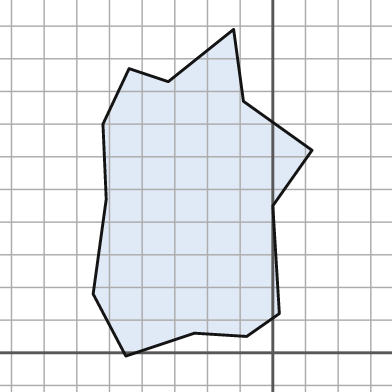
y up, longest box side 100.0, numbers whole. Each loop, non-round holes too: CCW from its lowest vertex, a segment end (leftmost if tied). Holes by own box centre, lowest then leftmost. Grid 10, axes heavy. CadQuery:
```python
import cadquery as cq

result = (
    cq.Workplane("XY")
    .moveTo(-45.0, -1.0)
    .lineTo(-24.0, 6.0)
    .lineTo(-8.0, 5.0)
    .lineTo(2.0, 12.0)
    .lineTo(0.0, 45.0)
    .lineTo(12.0, 62.0)
    .lineTo(-9.0, 77.0)
    .lineTo(-12.0, 99.0)
    .lineTo(-32.0, 83.0)
    .lineTo(-44.0, 87.0)
    .lineTo(-52.0, 70.0)
    .lineTo(-51.0, 47.0)
    .lineTo(-55.0, 18.0)
    .close()
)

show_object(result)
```